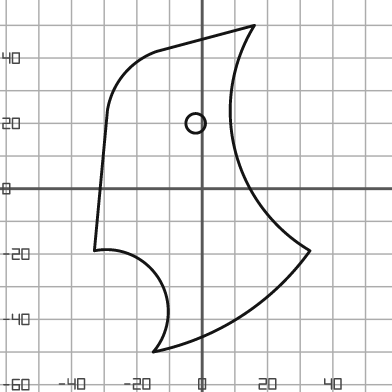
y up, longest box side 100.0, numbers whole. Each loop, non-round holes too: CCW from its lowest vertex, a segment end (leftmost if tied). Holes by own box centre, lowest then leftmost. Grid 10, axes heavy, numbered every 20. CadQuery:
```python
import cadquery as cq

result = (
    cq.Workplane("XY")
    .moveTo(-15.0, -50.0)
    .threePointArc((12.0, -39.0), (33.0, -19.0))
    .threePointArc((10.0, 12.0), (16.0, 50.0))
    .lineTo(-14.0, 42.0)
    .threePointArc((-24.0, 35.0), (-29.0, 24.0))
    .lineTo(-33.0, -19.0)
    .threePointArc((-13.0, -28.0), (-15.0, -50.0))
    .close()
    .moveTo(-2.0, 20.0)
    .circle(3.0)
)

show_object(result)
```